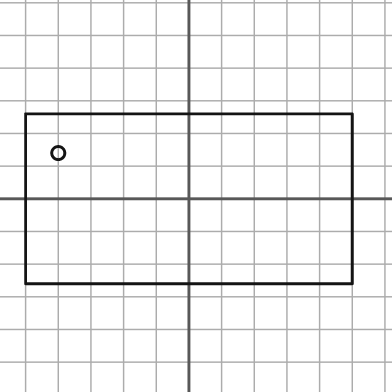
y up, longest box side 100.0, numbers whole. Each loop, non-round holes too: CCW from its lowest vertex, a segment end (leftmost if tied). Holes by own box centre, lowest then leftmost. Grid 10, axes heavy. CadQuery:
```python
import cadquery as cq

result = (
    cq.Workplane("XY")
    .moveTo(-50.0, -26.0)
    .lineTo(50.0, -26.0)
    .lineTo(50.0, 26.0)
    .lineTo(-50.0, 26.0)
    .close()
    .moveTo(-40.0, 14.0)
    .circle(2.0)
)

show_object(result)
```